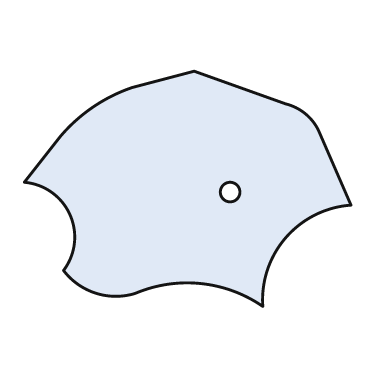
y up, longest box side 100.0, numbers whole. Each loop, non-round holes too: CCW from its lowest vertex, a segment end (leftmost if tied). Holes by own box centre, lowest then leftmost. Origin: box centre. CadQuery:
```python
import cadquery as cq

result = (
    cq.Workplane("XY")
    .moveTo(23.0, -36.0)
    .threePointArc((30.0, -15.0), (50.0, -5.0))
    .lineTo(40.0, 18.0)
    .threePointArc((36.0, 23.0), (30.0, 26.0))
    .lineTo(2.0, 36.0)
    .lineTo(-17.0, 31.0)
    .threePointArc((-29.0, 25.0), (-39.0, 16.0))
    .lineTo(-50.0, 2.0)
    .threePointArc((-36.0, -8.0), (-38.0, -25.0))
    .threePointArc((-28.0, -32.0), (-16.0, -32.0))
    .threePointArc((4.0, -29.0), (23.0, -36.0))
    .close()
    .moveTo(13.0, -1.0)
    .circle(3.0)
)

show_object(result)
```